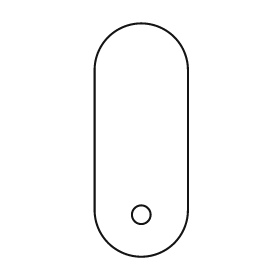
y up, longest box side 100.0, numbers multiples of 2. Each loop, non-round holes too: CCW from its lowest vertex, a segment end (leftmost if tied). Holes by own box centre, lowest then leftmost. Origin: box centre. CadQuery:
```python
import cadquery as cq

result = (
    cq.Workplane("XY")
    .moveTo(-20.0, -30.0)
    .threePointArc((0.0, -50.0), (20.0, -30.0))
    .lineTo(20.0, 30.0)
    .threePointArc((0.0, 50.0), (-20.0, 30.0))
    .close()
    .moveTo(0.0, -32.0)
    .circle(4.0)
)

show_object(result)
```